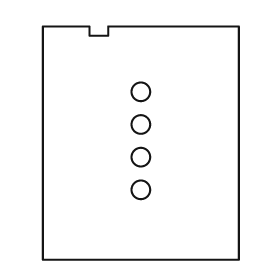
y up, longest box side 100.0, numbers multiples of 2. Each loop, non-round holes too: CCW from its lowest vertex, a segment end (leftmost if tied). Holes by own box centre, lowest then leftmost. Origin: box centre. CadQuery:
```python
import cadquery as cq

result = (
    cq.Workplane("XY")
    .moveTo(-42.0, -50.0)
    .lineTo(42.0, -50.0)
    .lineTo(42.0, 50.0)
    .lineTo(-14.0, 50.0)
    .lineTo(-14.0, 46.0)
    .lineTo(-22.0, 46.0)
    .lineTo(-22.0, 50.0)
    .lineTo(-42.0, 50.0)
    .close()
    .moveTo(0.0, -20.0)
    .circle(4.0)
    .moveTo(0.0, -6.0)
    .circle(4.0)
    .moveTo(0.0, 8.0)
    .circle(4.0)
    .moveTo(0.0, 22.0)
    .circle(4.0)
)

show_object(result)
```